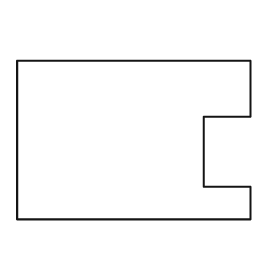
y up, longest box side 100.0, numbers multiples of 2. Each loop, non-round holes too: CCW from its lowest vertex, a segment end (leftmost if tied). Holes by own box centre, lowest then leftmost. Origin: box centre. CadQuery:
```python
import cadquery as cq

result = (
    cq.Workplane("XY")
    .moveTo(-50.0, -34.0)
    .lineTo(50.0, -34.0)
    .lineTo(50.0, -20.0)
    .lineTo(30.0, -20.0)
    .lineTo(30.0, 10.0)
    .lineTo(50.0, 10.0)
    .lineTo(50.0, 34.0)
    .lineTo(-50.0, 34.0)
    .close()
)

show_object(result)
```